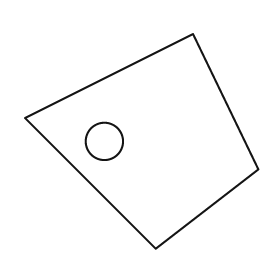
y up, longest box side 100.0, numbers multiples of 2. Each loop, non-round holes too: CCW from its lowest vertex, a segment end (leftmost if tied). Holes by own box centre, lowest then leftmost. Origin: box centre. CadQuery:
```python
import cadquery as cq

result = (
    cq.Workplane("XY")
    .moveTo(6.0, -46.0)
    .lineTo(50.0, -12.0)
    .lineTo(22.0, 46.0)
    .lineTo(-50.0, 10.0)
    .close()
    .moveTo(-16.0, 0.0)
    .circle(8.0)
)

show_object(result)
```